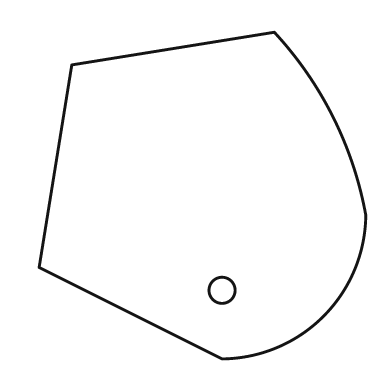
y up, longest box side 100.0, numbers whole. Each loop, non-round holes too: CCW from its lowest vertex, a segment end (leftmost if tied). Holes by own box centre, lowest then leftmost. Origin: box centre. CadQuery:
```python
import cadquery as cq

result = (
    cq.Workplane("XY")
    .moveTo(6.0, -50.0)
    .threePointArc((37.0, -37.0), (50.0, -6.0))
    .threePointArc((40.0, 24.0), (22.0, 50.0))
    .lineTo(-40.0, 40.0)
    .lineTo(-50.0, -22.0)
    .close()
    .moveTo(6.0, -29.0)
    .circle(4.0)
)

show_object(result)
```